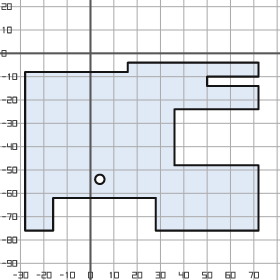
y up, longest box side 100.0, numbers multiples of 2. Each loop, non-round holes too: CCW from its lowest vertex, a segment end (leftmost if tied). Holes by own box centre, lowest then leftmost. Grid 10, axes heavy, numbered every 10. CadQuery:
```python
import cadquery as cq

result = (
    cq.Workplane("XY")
    .moveTo(-28.0, -76.0)
    .lineTo(-16.0, -76.0)
    .lineTo(-16.0, -62.0)
    .lineTo(28.0, -62.0)
    .lineTo(28.0, -76.0)
    .lineTo(72.0, -76.0)
    .lineTo(72.0, -48.0)
    .lineTo(36.0, -48.0)
    .lineTo(36.0, -24.0)
    .lineTo(72.0, -24.0)
    .lineTo(72.0, -14.0)
    .lineTo(50.0, -14.0)
    .lineTo(50.0, -10.0)
    .lineTo(72.0, -10.0)
    .lineTo(72.0, -4.0)
    .lineTo(16.0, -4.0)
    .lineTo(16.0, -8.0)
    .lineTo(-28.0, -8.0)
    .close()
    .moveTo(4.0, -54.0)
    .circle(2.0)
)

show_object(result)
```